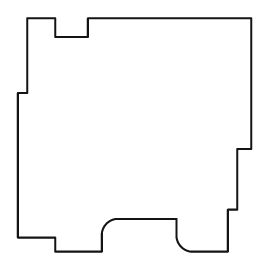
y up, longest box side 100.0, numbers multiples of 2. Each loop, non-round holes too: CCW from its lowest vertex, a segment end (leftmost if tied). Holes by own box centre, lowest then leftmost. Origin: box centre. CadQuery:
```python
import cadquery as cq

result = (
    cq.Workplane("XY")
    .moveTo(-34.0, -50.0)
    .lineTo(-14.0, -50.0)
    .lineTo(-14.0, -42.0)
    .threePointArc((-12.0, -38.0), (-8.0, -36.0))
    .lineTo(18.0, -36.0)
    .lineTo(18.0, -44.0)
    .threePointArc((20.0, -48.0), (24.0, -50.0))
    .lineTo(40.0, -50.0)
    .lineTo(40.0, -32.0)
    .lineTo(44.0, -32.0)
    .lineTo(44.0, -6.0)
    .lineTo(50.0, -6.0)
    .lineTo(50.0, 50.0)
    .lineTo(-20.0, 50.0)
    .lineTo(-20.0, 42.0)
    .lineTo(-34.0, 42.0)
    .lineTo(-34.0, 50.0)
    .lineTo(-46.0, 50.0)
    .lineTo(-46.0, 18.0)
    .lineTo(-50.0, 18.0)
    .lineTo(-50.0, -44.0)
    .lineTo(-34.0, -44.0)
    .close()
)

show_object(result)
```